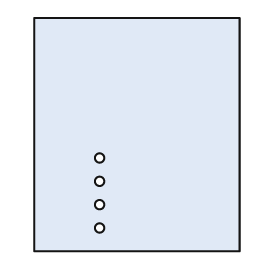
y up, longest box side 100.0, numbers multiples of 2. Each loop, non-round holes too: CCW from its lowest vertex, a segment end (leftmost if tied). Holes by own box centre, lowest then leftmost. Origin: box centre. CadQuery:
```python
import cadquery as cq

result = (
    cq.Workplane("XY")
    .moveTo(-44.0, -50.0)
    .lineTo(44.0, -50.0)
    .lineTo(44.0, 50.0)
    .lineTo(-44.0, 50.0)
    .close()
    .moveTo(-16.0, -40.0)
    .circle(2.0)
    .moveTo(-16.0, -30.0)
    .circle(2.0)
    .moveTo(-16.0, -20.0)
    .circle(2.0)
    .moveTo(-16.0, -10.0)
    .circle(2.0)
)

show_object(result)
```